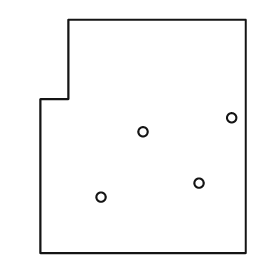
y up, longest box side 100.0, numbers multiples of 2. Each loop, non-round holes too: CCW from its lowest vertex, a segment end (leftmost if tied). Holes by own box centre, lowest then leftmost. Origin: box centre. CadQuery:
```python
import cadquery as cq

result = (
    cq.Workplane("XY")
    .moveTo(-44.0, -50.0)
    .lineTo(44.0, -50.0)
    .lineTo(44.0, 50.0)
    .lineTo(-32.0, 50.0)
    .lineTo(-32.0, 16.0)
    .lineTo(-44.0, 16.0)
    .close()
    .moveTo(-18.0, -26.0)
    .circle(2.0)
    .moveTo(24.0, -20.0)
    .circle(2.0)
    .moveTo(0.0, 2.0)
    .circle(2.0)
    .moveTo(38.0, 8.0)
    .circle(2.0)
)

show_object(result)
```